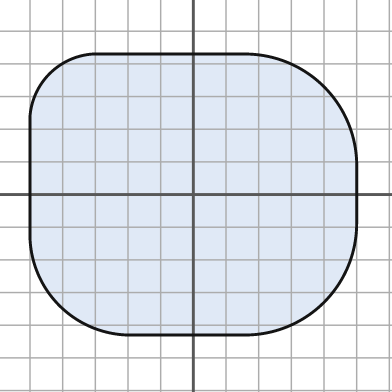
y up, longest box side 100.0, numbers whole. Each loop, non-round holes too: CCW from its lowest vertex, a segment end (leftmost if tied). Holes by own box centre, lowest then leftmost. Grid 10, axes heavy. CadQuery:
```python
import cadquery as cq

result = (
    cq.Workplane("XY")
    .moveTo(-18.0, -43.0)
    .lineTo(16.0, -43.0)
    .threePointArc((40.0, -33.0), (50.0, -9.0))
    .lineTo(50.0, 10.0)
    .threePointArc((40.0, 33.0), (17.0, 43.0))
    .lineTo(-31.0, 43.0)
    .threePointArc((-44.0, 37.0), (-50.0, 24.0))
    .lineTo(-50.0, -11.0)
    .threePointArc((-41.0, -34.0), (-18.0, -43.0))
    .close()
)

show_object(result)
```